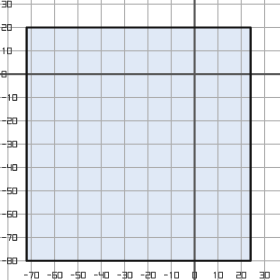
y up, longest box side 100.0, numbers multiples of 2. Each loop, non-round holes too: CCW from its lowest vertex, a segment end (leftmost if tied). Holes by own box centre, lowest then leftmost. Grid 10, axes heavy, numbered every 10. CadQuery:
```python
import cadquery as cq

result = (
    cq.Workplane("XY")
    .moveTo(-72.0, -80.0)
    .lineTo(24.0, -80.0)
    .lineTo(24.0, 20.0)
    .lineTo(-72.0, 20.0)
    .close()
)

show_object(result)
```